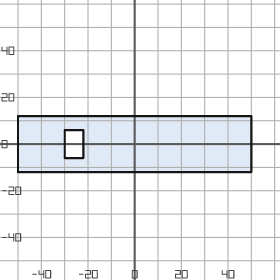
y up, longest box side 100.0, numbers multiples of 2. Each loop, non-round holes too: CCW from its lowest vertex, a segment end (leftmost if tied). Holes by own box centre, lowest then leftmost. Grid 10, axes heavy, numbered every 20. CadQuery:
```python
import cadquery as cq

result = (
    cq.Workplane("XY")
    .moveTo(-50.0, -12.0)
    .lineTo(50.0, -12.0)
    .lineTo(50.0, 12.0)
    .lineTo(-50.0, 12.0)
    .close()
    .moveTo(-30.0, -6.0)
    .lineTo(-22.0, -6.0)
    .lineTo(-22.0, 6.0)
    .lineTo(-30.0, 6.0)
    .close()
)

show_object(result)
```